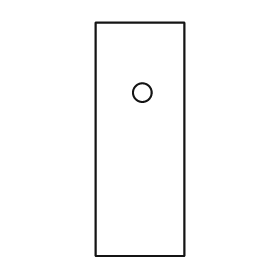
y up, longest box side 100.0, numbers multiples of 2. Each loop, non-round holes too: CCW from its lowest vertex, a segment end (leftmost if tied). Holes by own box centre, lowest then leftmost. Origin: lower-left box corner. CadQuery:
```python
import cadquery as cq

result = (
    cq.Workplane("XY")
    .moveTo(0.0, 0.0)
    .lineTo(38.0, 0.0)
    .lineTo(38.0, 100.0)
    .lineTo(0.0, 100.0)
    .close()
    .moveTo(20.0, 70.0)
    .circle(4.0)
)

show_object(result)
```